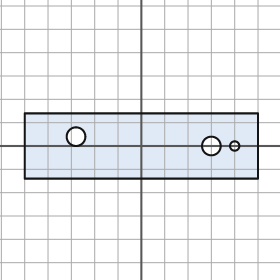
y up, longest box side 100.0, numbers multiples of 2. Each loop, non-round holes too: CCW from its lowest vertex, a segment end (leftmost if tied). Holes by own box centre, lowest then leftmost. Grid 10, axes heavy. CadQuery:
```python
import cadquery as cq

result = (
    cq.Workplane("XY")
    .moveTo(-50.0, -14.0)
    .lineTo(50.0, -14.0)
    .lineTo(50.0, 14.0)
    .lineTo(-50.0, 14.0)
    .close()
    .moveTo(30.0, 0.0)
    .circle(4.0)
    .moveTo(40.0, 0.0)
    .circle(2.0)
    .moveTo(-28.0, 4.0)
    .circle(4.0)
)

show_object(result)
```